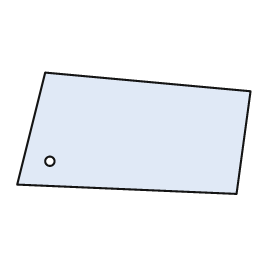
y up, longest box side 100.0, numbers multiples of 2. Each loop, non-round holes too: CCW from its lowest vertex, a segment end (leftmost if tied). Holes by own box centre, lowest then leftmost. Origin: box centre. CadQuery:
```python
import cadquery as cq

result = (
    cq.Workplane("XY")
    .moveTo(44.0, -26.0)
    .lineTo(50.0, 18.0)
    .lineTo(-38.0, 26.0)
    .lineTo(-50.0, -22.0)
    .close()
    .moveTo(-36.0, -12.0)
    .circle(2.0)
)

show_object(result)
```